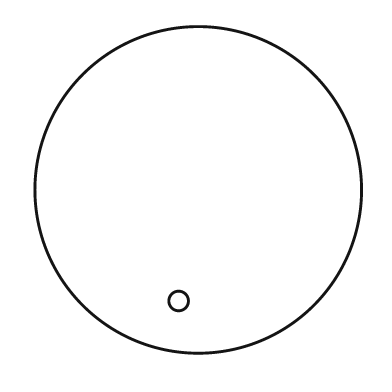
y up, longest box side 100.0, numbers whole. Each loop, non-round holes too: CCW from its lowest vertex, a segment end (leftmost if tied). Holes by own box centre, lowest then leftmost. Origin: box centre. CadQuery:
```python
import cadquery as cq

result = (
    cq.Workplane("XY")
    .moveTo(0.0, 0.0)
    .circle(50.0)
    .moveTo(-6.0, -34.0)
    .circle(3.0)
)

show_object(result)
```